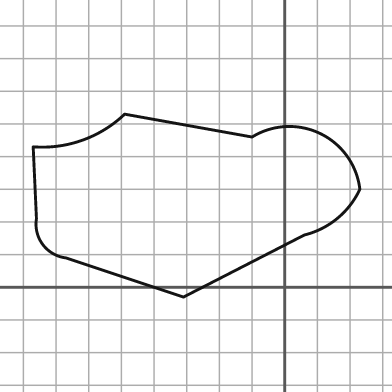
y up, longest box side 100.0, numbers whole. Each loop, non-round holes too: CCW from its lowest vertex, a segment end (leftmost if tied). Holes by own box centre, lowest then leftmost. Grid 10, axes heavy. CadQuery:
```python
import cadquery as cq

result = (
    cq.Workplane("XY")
    .moveTo(-31.0, -3.0)
    .lineTo(6.0, 16.0)
    .threePointArc((16.0, 21.0), (23.0, 30.0))
    .threePointArc((11.0, 47.0), (-10.0, 46.0))
    .lineTo(-49.0, 53.0)
    .threePointArc((-62.0, 45.0), (-77.0, 43.0))
    .lineTo(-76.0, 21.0)
    .threePointArc((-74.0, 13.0), (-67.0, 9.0))
    .close()
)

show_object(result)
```